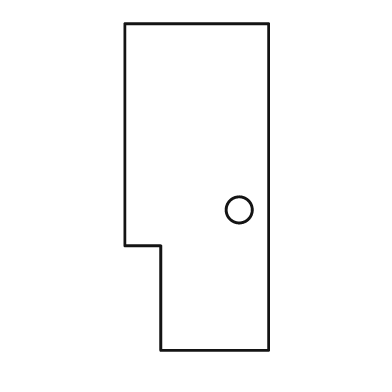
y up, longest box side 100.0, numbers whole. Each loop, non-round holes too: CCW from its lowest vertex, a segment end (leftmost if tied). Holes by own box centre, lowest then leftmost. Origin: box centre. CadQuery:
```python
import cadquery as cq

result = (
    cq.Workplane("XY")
    .moveTo(-11.0, -50.0)
    .lineTo(22.0, -50.0)
    .lineTo(22.0, 50.0)
    .lineTo(-22.0, 50.0)
    .lineTo(-22.0, -18.0)
    .lineTo(-11.0, -18.0)
    .close()
    .moveTo(13.0, -7.0)
    .circle(4.0)
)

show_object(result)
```